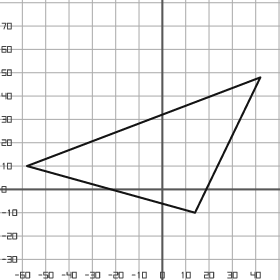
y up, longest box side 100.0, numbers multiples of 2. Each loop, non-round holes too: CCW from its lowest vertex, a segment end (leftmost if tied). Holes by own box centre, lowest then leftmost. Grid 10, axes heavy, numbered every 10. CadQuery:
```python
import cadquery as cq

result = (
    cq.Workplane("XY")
    .moveTo(14.0, -10.0)
    .lineTo(42.0, 48.0)
    .lineTo(-58.0, 10.0)
    .close()
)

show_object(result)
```